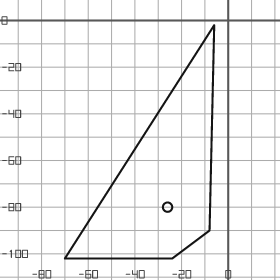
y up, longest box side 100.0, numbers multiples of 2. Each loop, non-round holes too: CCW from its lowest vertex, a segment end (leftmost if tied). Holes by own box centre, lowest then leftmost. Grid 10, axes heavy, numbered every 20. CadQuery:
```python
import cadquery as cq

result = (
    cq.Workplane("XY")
    .moveTo(-70.0, -102.0)
    .lineTo(-24.0, -102.0)
    .lineTo(-8.0, -90.0)
    .lineTo(-6.0, -2.0)
    .close()
    .moveTo(-26.0, -80.0)
    .circle(2.0)
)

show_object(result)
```